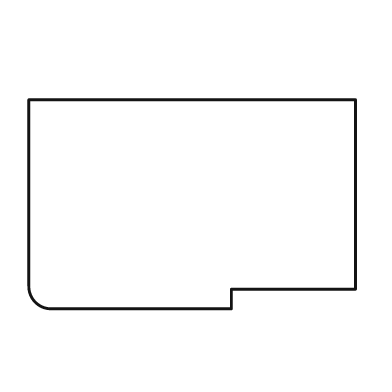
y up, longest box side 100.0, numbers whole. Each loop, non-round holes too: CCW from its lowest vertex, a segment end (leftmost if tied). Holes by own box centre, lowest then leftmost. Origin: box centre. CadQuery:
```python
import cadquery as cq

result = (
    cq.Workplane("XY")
    .moveTo(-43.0, -32.0)
    .lineTo(12.0, -32.0)
    .lineTo(12.0, -26.0)
    .lineTo(50.0, -26.0)
    .lineTo(50.0, 32.0)
    .lineTo(-50.0, 32.0)
    .lineTo(-50.0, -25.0)
    .threePointArc((-48.0, -30.0), (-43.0, -32.0))
    .close()
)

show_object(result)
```